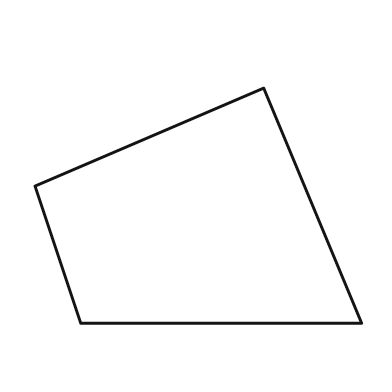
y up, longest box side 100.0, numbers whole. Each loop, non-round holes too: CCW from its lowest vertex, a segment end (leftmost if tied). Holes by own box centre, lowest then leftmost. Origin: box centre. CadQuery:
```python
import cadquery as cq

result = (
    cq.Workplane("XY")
    .moveTo(-36.0, -36.0)
    .lineTo(50.0, -36.0)
    .lineTo(20.0, 36.0)
    .lineTo(-50.0, 6.0)
    .close()
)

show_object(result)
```